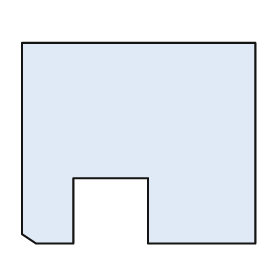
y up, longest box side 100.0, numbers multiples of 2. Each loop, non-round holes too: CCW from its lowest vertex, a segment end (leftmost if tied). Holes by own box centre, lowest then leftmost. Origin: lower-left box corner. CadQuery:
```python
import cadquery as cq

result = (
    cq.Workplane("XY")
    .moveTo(6.0, 0.0)
    .lineTo(22.0, 0.0)
    .lineTo(22.0, 28.0)
    .lineTo(54.0, 28.0)
    .lineTo(54.0, 0.0)
    .lineTo(100.0, 0.0)
    .lineTo(100.0, 86.0)
    .lineTo(0.0, 86.0)
    .lineTo(0.0, 4.0)
    .close()
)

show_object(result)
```